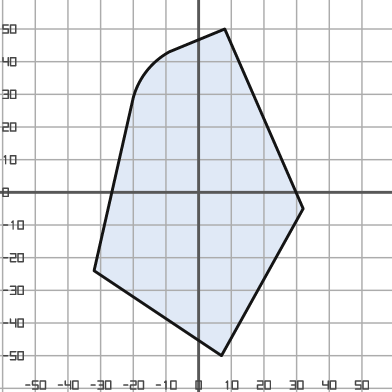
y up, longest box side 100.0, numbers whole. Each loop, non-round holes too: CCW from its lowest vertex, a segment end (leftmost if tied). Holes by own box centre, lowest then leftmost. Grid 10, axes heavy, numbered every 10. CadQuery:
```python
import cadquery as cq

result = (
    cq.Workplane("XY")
    .moveTo(7.0, -50.0)
    .lineTo(32.0, -5.0)
    .lineTo(8.0, 50.0)
    .lineTo(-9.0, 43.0)
    .threePointArc((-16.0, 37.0), (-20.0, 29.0))
    .lineTo(-32.0, -24.0)
    .close()
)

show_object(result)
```